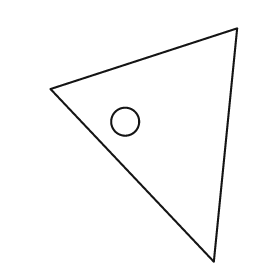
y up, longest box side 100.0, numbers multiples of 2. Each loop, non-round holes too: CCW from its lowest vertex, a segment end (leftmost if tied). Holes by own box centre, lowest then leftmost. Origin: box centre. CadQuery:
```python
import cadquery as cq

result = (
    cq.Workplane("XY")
    .moveTo(30.0, -50.0)
    .lineTo(40.0, 50.0)
    .lineTo(-40.0, 24.0)
    .close()
    .moveTo(-8.0, 10.0)
    .circle(6.0)
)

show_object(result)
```